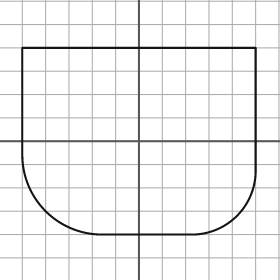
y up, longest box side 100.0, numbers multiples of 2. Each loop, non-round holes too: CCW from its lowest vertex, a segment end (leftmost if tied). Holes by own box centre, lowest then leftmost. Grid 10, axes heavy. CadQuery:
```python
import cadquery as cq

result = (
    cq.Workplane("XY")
    .moveTo(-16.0, -40.0)
    .lineTo(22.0, -40.0)
    .threePointArc((42.0, -32.0), (50.0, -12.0))
    .lineTo(50.0, 40.0)
    .lineTo(-50.0, 40.0)
    .lineTo(-50.0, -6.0)
    .threePointArc((-40.0, -30.0), (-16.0, -40.0))
    .close()
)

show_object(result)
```